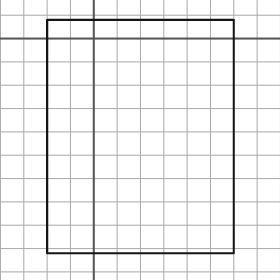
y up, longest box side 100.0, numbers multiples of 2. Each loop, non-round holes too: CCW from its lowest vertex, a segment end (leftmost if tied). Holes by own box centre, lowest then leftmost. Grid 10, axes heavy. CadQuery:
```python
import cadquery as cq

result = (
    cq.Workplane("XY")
    .moveTo(-20.0, -92.0)
    .lineTo(60.0, -92.0)
    .lineTo(60.0, 8.0)
    .lineTo(-20.0, 8.0)
    .close()
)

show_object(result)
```